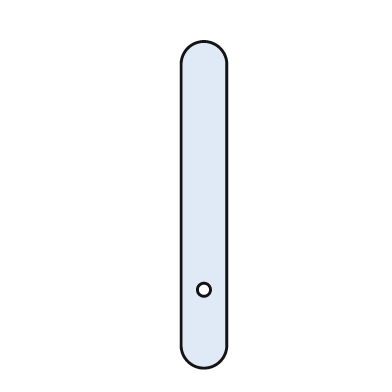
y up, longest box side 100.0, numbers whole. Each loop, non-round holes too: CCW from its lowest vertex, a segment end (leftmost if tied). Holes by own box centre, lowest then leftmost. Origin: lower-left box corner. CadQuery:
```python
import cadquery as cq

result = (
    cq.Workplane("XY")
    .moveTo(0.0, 7.0)
    .threePointArc((7.0, 0.0), (14.0, 7.0))
    .lineTo(14.0, 93.0)
    .threePointArc((7.0, 100.0), (0.0, 93.0))
    .close()
    .moveTo(7.0, 24.0)
    .circle(2.0)
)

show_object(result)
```